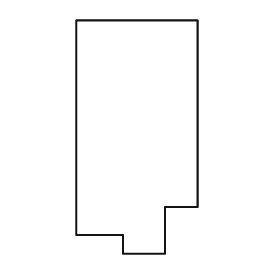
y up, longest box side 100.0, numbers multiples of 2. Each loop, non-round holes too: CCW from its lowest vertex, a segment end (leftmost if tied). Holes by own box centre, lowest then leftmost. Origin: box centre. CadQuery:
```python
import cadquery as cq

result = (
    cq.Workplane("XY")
    .moveTo(-6.0, -50.0)
    .lineTo(12.0, -50.0)
    .lineTo(12.0, -30.0)
    .lineTo(26.0, -30.0)
    .lineTo(26.0, 50.0)
    .lineTo(-26.0, 50.0)
    .lineTo(-26.0, -42.0)
    .lineTo(-6.0, -42.0)
    .close()
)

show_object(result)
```